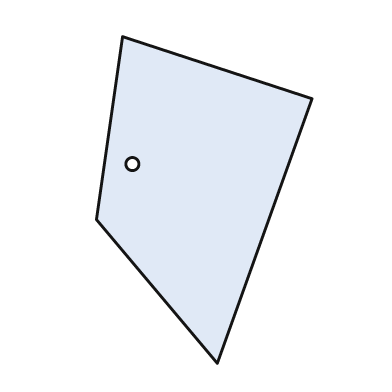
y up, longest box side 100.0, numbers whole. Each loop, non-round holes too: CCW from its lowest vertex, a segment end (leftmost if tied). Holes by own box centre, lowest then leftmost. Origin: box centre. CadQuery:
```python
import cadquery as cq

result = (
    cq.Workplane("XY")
    .moveTo(4.0, -50.0)
    .lineTo(33.0, 31.0)
    .lineTo(-25.0, 50.0)
    .lineTo(-33.0, -6.0)
    .close()
    .moveTo(-22.0, 11.0)
    .circle(2.0)
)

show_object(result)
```